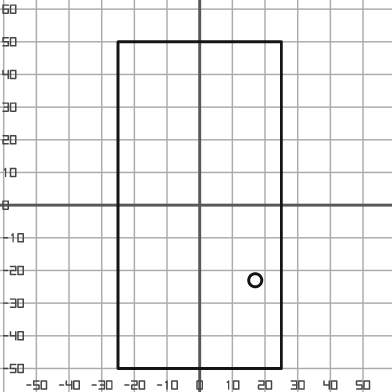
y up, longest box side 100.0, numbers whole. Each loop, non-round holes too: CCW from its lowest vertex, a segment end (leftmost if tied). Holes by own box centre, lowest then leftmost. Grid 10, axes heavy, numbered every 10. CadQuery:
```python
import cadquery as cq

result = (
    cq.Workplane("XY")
    .moveTo(-25.0, -50.0)
    .lineTo(25.0, -50.0)
    .lineTo(25.0, 50.0)
    .lineTo(-25.0, 50.0)
    .close()
    .moveTo(17.0, -23.0)
    .circle(2.0)
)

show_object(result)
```